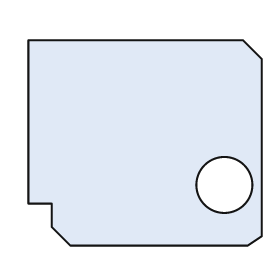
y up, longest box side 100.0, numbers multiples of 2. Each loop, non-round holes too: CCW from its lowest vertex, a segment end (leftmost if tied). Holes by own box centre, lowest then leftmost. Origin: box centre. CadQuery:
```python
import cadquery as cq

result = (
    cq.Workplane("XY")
    .moveTo(-32.0, -44.0)
    .lineTo(44.0, -44.0)
    .lineTo(50.0, -40.0)
    .lineTo(50.0, 36.0)
    .lineTo(42.0, 44.0)
    .lineTo(-50.0, 44.0)
    .lineTo(-50.0, -26.0)
    .lineTo(-40.0, -26.0)
    .lineTo(-40.0, -36.0)
    .close()
    .moveTo(34.0, -18.0)
    .circle(12.0)
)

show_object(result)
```